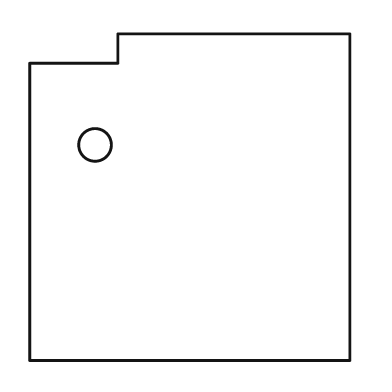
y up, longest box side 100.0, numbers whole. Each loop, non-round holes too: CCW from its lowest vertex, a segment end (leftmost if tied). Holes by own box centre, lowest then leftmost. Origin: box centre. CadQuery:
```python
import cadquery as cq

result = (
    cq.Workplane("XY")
    .moveTo(-49.0, -50.0)
    .lineTo(49.0, -50.0)
    .lineTo(49.0, 50.0)
    .lineTo(-22.0, 50.0)
    .lineTo(-22.0, 41.0)
    .lineTo(-49.0, 41.0)
    .close()
    .moveTo(-29.0, 16.0)
    .circle(5.0)
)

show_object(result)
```